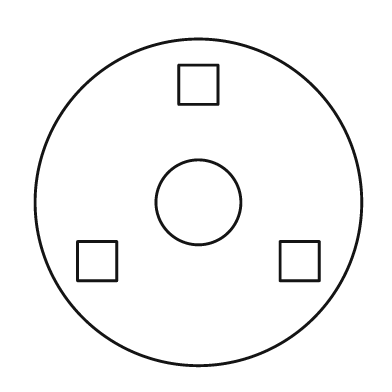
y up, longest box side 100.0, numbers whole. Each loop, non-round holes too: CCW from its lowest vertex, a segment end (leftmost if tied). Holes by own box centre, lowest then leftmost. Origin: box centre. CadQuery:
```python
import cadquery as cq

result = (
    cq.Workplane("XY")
    .moveTo(0.0, 0.0)
    .circle(50.0)
    .moveTo(-37.0, -24.0)
    .lineTo(-25.0, -24.0)
    .lineTo(-25.0, -12.0)
    .lineTo(-37.0, -12.0)
    .close()
    .moveTo(25.0, -24.0)
    .lineTo(37.0, -24.0)
    .lineTo(37.0, -12.0)
    .lineTo(25.0, -12.0)
    .close()
    .moveTo(0.0, 0.0)
    .circle(13.0)
    .moveTo(-6.0, 30.0)
    .lineTo(6.0, 30.0)
    .lineTo(6.0, 42.0)
    .lineTo(-6.0, 42.0)
    .close()
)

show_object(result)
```